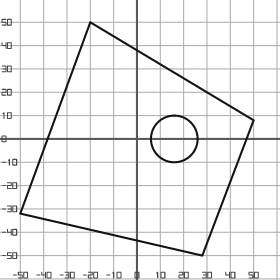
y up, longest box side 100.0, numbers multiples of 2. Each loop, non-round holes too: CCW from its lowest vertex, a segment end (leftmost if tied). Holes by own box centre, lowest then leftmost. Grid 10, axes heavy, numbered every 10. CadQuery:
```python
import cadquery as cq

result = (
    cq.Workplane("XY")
    .moveTo(28.0, -50.0)
    .lineTo(50.0, 8.0)
    .lineTo(-20.0, 50.0)
    .lineTo(-50.0, -32.0)
    .close()
    .moveTo(16.0, 0.0)
    .circle(10.0)
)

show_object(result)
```